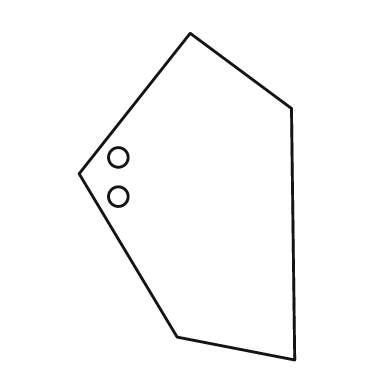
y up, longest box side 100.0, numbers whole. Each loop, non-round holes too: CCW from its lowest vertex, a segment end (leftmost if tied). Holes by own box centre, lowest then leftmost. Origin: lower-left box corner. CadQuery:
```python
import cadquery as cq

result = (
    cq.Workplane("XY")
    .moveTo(66.0, 0.0)
    .lineTo(65.0, 77.0)
    .lineTo(34.0, 100.0)
    .lineTo(0.0, 57.0)
    .lineTo(30.0, 7.0)
    .close()
    .moveTo(12.0, 50.0)
    .circle(3.0)
    .moveTo(12.0, 62.0)
    .circle(3.0)
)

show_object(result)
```